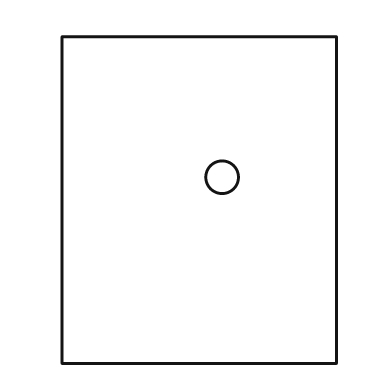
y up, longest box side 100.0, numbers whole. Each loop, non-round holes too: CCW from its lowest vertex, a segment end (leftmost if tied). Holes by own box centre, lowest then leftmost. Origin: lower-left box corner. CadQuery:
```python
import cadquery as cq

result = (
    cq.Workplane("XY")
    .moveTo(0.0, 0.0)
    .lineTo(84.0, 0.0)
    .lineTo(84.0, 100.0)
    .lineTo(0.0, 100.0)
    .close()
    .moveTo(49.0, 57.0)
    .circle(5.0)
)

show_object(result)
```